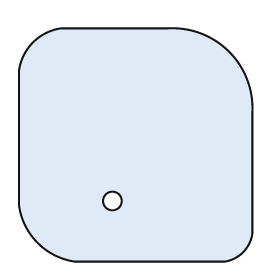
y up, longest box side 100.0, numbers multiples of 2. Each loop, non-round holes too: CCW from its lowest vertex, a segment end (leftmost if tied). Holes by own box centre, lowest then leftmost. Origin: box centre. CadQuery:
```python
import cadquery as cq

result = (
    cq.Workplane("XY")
    .moveTo(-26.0, -50.0)
    .lineTo(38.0, -50.0)
    .threePointArc((46.0, -46.0), (50.0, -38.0))
    .lineTo(50.0, 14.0)
    .threePointArc((40.0, 40.0), (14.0, 50.0))
    .lineTo(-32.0, 50.0)
    .threePointArc((-44.0, 44.0), (-50.0, 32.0))
    .lineTo(-50.0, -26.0)
    .threePointArc((-42.0, -42.0), (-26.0, -50.0))
    .close()
    .moveTo(-10.0, -24.0)
    .circle(4.0)
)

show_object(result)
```